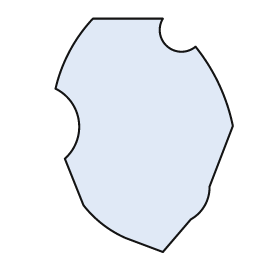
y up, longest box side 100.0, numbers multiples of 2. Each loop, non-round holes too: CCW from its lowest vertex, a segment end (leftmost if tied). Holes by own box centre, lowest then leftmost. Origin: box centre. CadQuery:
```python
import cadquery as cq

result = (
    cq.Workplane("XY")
    .moveTo(8.0, -50.0)
    .lineTo(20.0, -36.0)
    .threePointArc((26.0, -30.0), (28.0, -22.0))
    .lineTo(38.0, 4.0)
    .threePointArc((32.0, 22.0), (22.0, 38.0))
    .threePointArc((10.0, 38.0), (8.0, 50.0))
    .lineTo(-22.0, 50.0)
    .threePointArc((-32.0, 36.0), (-38.0, 20.0))
    .threePointArc((-28.0, 6.0), (-34.0, -10.0))
    .lineTo(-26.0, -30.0)
    .threePointArc((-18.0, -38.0), (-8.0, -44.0))
    .close()
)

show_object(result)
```